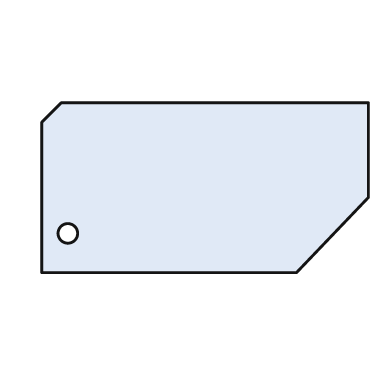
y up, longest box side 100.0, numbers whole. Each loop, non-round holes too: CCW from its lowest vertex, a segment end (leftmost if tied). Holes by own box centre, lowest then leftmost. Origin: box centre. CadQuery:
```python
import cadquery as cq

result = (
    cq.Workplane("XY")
    .moveTo(-50.0, -26.0)
    .lineTo(28.0, -26.0)
    .lineTo(50.0, -3.0)
    .lineTo(50.0, 26.0)
    .lineTo(-44.0, 26.0)
    .lineTo(-50.0, 20.0)
    .close()
    .moveTo(-42.0, -14.0)
    .circle(3.0)
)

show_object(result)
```